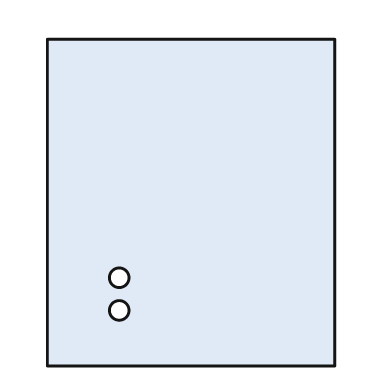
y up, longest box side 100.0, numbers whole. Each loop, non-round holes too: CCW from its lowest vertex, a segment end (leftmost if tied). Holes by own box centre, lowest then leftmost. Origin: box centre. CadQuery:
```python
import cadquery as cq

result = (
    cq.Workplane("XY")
    .moveTo(-44.0, -50.0)
    .lineTo(44.0, -50.0)
    .lineTo(44.0, 50.0)
    .lineTo(-44.0, 50.0)
    .close()
    .moveTo(-22.0, -33.0)
    .circle(3.0)
    .moveTo(-22.0, -23.0)
    .circle(3.0)
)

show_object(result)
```